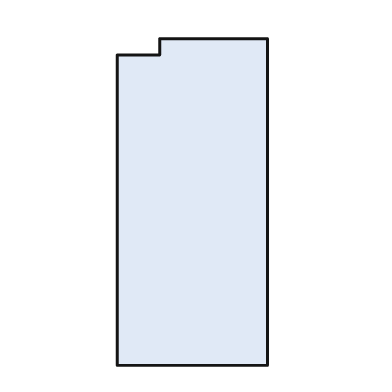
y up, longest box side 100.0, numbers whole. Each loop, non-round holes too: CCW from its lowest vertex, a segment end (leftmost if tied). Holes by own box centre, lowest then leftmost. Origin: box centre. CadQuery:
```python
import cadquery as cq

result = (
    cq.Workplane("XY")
    .moveTo(-23.0, -50.0)
    .lineTo(23.0, -50.0)
    .lineTo(23.0, 50.0)
    .lineTo(-10.0, 50.0)
    .lineTo(-10.0, 45.0)
    .lineTo(-23.0, 45.0)
    .close()
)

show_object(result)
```